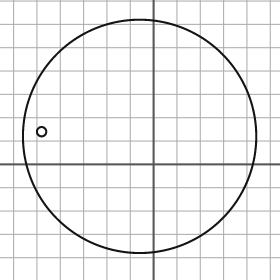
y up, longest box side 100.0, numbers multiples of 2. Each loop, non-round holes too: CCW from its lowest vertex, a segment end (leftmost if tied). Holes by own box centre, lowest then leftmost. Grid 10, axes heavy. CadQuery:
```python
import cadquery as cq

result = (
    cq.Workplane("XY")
    .moveTo(-6.0, 12.0)
    .circle(50.0)
    .moveTo(-48.0, 14.0)
    .circle(2.0)
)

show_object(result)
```